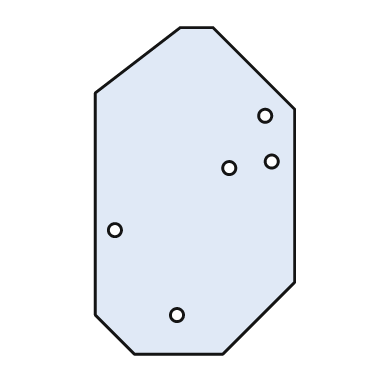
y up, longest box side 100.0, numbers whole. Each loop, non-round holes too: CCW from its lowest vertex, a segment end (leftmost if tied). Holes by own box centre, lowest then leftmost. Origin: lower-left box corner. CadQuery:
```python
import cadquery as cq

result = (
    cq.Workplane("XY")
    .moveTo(12.0, 0.0)
    .lineTo(39.0, 0.0)
    .lineTo(61.0, 22.0)
    .lineTo(61.0, 75.0)
    .lineTo(36.0, 100.0)
    .lineTo(26.0, 100.0)
    .lineTo(0.0, 80.0)
    .lineTo(0.0, 12.0)
    .close()
    .moveTo(25.0, 12.0)
    .circle(2.0)
    .moveTo(6.0, 38.0)
    .circle(2.0)
    .moveTo(41.0, 57.0)
    .circle(2.0)
    .moveTo(54.0, 59.0)
    .circle(2.0)
    .moveTo(52.0, 73.0)
    .circle(2.0)
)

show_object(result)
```